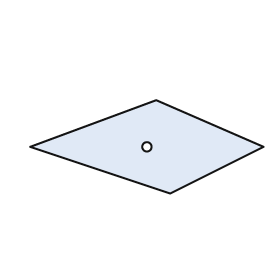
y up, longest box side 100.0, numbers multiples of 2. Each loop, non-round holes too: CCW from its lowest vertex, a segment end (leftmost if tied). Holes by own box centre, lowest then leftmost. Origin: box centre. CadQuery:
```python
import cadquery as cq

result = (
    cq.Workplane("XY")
    .moveTo(10.0, -20.0)
    .lineTo(50.0, 0.0)
    .lineTo(4.0, 20.0)
    .lineTo(-50.0, 0.0)
    .close()
    .moveTo(0.0, 0.0)
    .circle(2.0)
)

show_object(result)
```